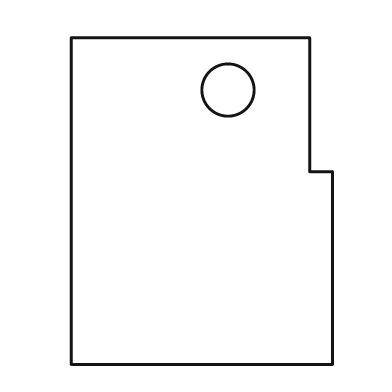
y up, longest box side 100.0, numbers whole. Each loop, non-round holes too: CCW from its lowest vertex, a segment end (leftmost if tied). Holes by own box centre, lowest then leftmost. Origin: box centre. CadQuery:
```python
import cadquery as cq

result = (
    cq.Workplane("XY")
    .moveTo(-40.0, -50.0)
    .lineTo(40.0, -50.0)
    .lineTo(40.0, 9.0)
    .lineTo(33.0, 9.0)
    .lineTo(33.0, 50.0)
    .lineTo(-40.0, 50.0)
    .close()
    .moveTo(8.0, 34.0)
    .circle(8.0)
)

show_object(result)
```